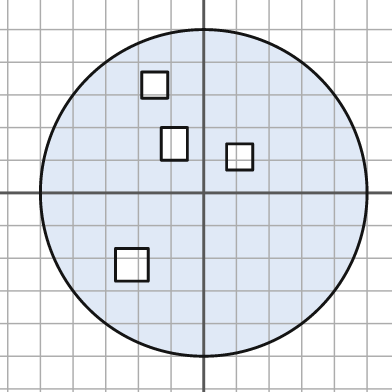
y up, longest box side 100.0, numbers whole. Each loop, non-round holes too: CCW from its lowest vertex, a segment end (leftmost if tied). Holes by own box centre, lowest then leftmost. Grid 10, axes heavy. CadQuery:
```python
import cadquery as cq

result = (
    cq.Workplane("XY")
    .moveTo(0.0, 0.0)
    .circle(50.0)
    .moveTo(-27.0, -27.0)
    .lineTo(-17.0, -27.0)
    .lineTo(-17.0, -17.0)
    .lineTo(-27.0, -17.0)
    .close()
    .moveTo(7.0, 7.0)
    .lineTo(15.0, 7.0)
    .lineTo(15.0, 15.0)
    .lineTo(7.0, 15.0)
    .close()
    .moveTo(-13.0, 10.0)
    .lineTo(-5.0, 10.0)
    .lineTo(-5.0, 20.0)
    .lineTo(-13.0, 20.0)
    .close()
    .moveTo(-19.0, 29.0)
    .lineTo(-11.0, 29.0)
    .lineTo(-11.0, 37.0)
    .lineTo(-19.0, 37.0)
    .close()
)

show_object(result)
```